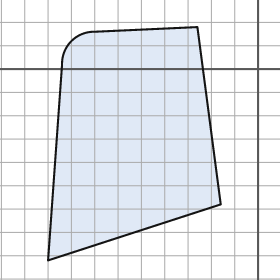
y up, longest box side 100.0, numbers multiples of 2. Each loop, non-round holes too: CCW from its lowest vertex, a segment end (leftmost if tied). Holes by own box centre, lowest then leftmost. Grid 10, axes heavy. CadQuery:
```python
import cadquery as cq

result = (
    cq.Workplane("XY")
    .moveTo(-90.0, -82.0)
    .lineTo(-16.0, -58.0)
    .lineTo(-26.0, 18.0)
    .lineTo(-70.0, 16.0)
    .threePointArc((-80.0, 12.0), (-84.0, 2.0))
    .close()
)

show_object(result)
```